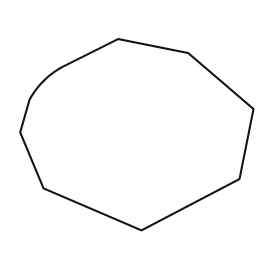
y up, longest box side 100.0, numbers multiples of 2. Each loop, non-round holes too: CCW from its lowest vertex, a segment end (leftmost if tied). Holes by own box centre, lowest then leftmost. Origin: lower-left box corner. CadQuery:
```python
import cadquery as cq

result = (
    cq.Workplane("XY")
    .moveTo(52.0, 0.0)
    .lineTo(94.0, 22.0)
    .lineTo(100.0, 52.0)
    .lineTo(72.0, 76.0)
    .lineTo(42.0, 82.0)
    .lineTo(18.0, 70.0)
    .threePointArc((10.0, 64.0), (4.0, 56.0))
    .lineTo(0.0, 42.0)
    .lineTo(10.0, 18.0)
    .close()
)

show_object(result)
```